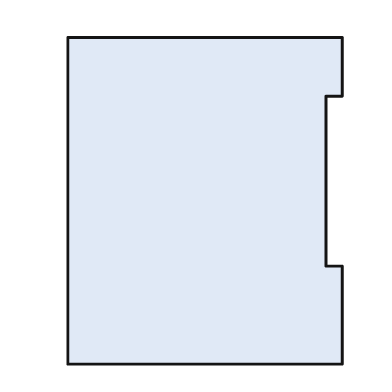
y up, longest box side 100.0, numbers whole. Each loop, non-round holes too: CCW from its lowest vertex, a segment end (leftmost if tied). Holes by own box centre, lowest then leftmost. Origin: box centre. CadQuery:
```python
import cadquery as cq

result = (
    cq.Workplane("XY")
    .moveTo(-42.0, -50.0)
    .lineTo(42.0, -50.0)
    .lineTo(42.0, -20.0)
    .lineTo(37.0, -20.0)
    .lineTo(37.0, 32.0)
    .lineTo(42.0, 32.0)
    .lineTo(42.0, 50.0)
    .lineTo(-42.0, 50.0)
    .close()
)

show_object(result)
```